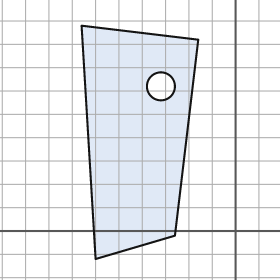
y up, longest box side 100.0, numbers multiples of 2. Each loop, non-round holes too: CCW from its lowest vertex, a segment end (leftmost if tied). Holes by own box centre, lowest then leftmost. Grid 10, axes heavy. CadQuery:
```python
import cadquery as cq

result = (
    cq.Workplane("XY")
    .moveTo(-60.0, -12.0)
    .lineTo(-26.0, -2.0)
    .lineTo(-16.0, 82.0)
    .lineTo(-66.0, 88.0)
    .close()
    .moveTo(-32.0, 62.0)
    .circle(6.0)
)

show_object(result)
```